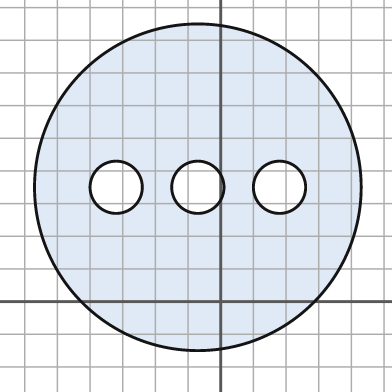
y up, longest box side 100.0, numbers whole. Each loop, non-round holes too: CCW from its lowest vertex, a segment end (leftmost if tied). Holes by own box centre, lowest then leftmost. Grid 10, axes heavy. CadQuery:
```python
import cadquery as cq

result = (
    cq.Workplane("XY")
    .moveTo(-7.0, 35.0)
    .circle(50.0)
    .moveTo(-32.0, 35.0)
    .circle(8.0)
    .moveTo(-7.0, 35.0)
    .circle(8.0)
    .moveTo(18.0, 35.0)
    .circle(8.0)
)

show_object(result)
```